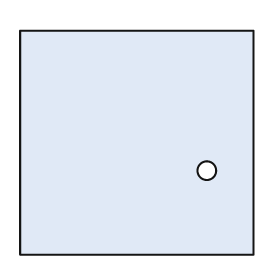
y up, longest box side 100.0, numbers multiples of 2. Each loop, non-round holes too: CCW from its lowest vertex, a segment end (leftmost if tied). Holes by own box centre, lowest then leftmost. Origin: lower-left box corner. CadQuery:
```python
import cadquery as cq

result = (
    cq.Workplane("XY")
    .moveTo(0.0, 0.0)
    .lineTo(100.0, 0.0)
    .lineTo(100.0, 96.0)
    .lineTo(0.0, 96.0)
    .close()
    .moveTo(80.0, 36.0)
    .circle(4.0)
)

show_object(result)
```